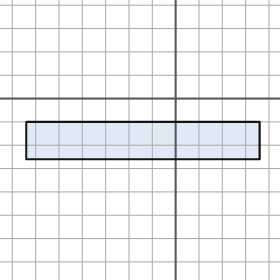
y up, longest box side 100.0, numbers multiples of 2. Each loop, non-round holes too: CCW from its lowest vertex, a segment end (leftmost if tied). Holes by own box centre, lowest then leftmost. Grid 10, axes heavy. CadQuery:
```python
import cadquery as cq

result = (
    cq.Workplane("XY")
    .moveTo(-64.0, -26.0)
    .lineTo(36.0, -26.0)
    .lineTo(36.0, -10.0)
    .lineTo(-64.0, -10.0)
    .close()
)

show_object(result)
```